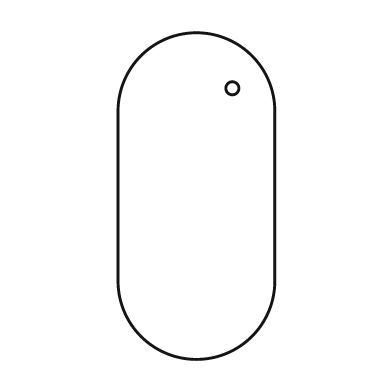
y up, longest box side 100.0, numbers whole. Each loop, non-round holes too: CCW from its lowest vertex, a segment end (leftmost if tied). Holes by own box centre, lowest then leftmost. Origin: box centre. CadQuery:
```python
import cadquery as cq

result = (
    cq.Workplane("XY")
    .moveTo(-24.0, -26.0)
    .threePointArc((0.0, -50.0), (24.0, -26.0))
    .lineTo(24.0, 26.0)
    .threePointArc((0.0, 50.0), (-24.0, 26.0))
    .close()
    .moveTo(11.0, 33.0)
    .circle(2.0)
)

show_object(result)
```